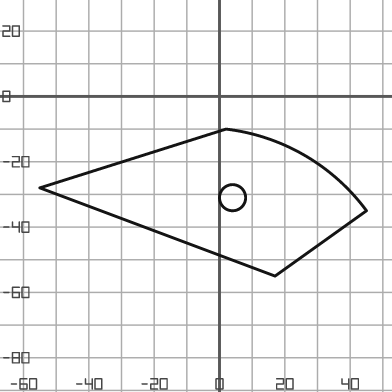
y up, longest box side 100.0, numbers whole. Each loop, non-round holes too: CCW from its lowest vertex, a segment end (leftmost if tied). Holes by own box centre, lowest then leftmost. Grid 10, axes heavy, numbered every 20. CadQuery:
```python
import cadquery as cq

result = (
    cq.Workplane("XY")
    .moveTo(17.0, -55.0)
    .lineTo(45.0, -35.0)
    .threePointArc((26.0, -18.0), (2.0, -10.0))
    .lineTo(-55.0, -28.0)
    .close()
    .moveTo(4.0, -31.0)
    .circle(4.0)
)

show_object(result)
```